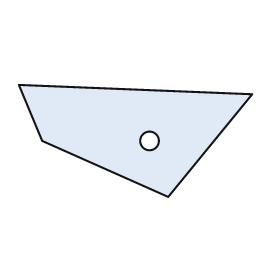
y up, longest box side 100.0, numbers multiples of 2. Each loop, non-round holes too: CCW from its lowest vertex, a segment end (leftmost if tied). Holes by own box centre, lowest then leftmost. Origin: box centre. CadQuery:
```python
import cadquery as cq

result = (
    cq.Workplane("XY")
    .moveTo(14.0, -24.0)
    .lineTo(50.0, 20.0)
    .lineTo(-50.0, 24.0)
    .lineTo(-40.0, 0.0)
    .close()
    .moveTo(6.0, 0.0)
    .circle(4.0)
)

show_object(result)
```